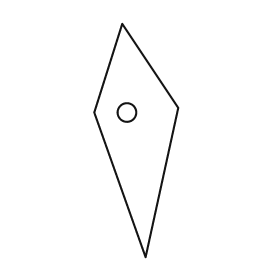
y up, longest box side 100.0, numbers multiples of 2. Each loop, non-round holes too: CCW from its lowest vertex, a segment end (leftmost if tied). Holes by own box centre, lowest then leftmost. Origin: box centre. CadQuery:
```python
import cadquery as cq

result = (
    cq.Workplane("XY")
    .moveTo(4.0, -50.0)
    .lineTo(18.0, 14.0)
    .lineTo(-6.0, 50.0)
    .lineTo(-18.0, 12.0)
    .close()
    .moveTo(-4.0, 12.0)
    .circle(4.0)
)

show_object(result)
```